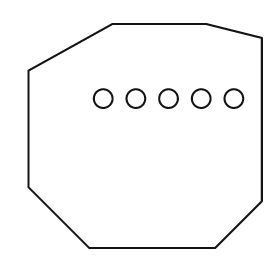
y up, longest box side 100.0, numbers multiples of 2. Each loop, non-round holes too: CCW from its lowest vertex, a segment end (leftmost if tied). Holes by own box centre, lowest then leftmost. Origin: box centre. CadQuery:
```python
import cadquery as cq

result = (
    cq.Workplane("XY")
    .moveTo(-24.0, -48.0)
    .lineTo(30.0, -48.0)
    .lineTo(50.0, -28.0)
    .lineTo(50.0, 42.0)
    .lineTo(26.0, 48.0)
    .lineTo(-14.0, 48.0)
    .lineTo(-50.0, 28.0)
    .lineTo(-50.0, -22.0)
    .close()
    .moveTo(-18.0, 16.0)
    .circle(4.0)
    .moveTo(-4.0, 16.0)
    .circle(4.0)
    .moveTo(10.0, 16.0)
    .circle(4.0)
    .moveTo(24.0, 16.0)
    .circle(4.0)
    .moveTo(38.0, 16.0)
    .circle(4.0)
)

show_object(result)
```